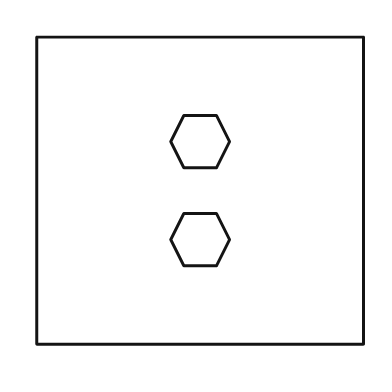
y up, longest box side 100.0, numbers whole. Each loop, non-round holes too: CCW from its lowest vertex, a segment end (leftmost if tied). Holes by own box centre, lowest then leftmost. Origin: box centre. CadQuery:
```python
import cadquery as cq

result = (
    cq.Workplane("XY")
    .moveTo(-50.0, -47.0)
    .lineTo(50.0, -47.0)
    .lineTo(50.0, 47.0)
    .lineTo(-50.0, 47.0)
    .close()
    .moveTo(-5.0, -23.0)
    .lineTo(5.0, -23.0)
    .lineTo(9.0, -15.0)
    .lineTo(5.0, -7.0)
    .lineTo(-5.0, -7.0)
    .lineTo(-9.0, -15.0)
    .close()
    .moveTo(-5.0, 7.0)
    .lineTo(5.0, 7.0)
    .lineTo(9.0, 15.0)
    .lineTo(5.0, 23.0)
    .lineTo(-5.0, 23.0)
    .lineTo(-9.0, 15.0)
    .close()
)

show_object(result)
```